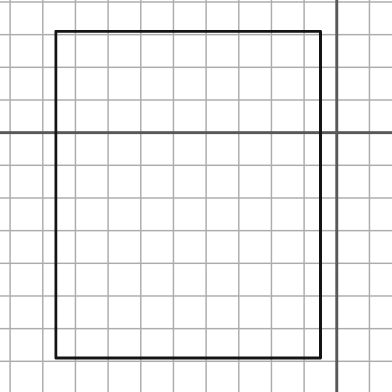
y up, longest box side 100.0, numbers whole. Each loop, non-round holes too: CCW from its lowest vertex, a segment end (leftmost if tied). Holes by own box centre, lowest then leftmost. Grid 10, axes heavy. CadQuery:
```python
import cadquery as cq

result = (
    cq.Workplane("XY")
    .moveTo(-86.0, -69.0)
    .lineTo(-5.0, -69.0)
    .lineTo(-5.0, 31.0)
    .lineTo(-86.0, 31.0)
    .close()
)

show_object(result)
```